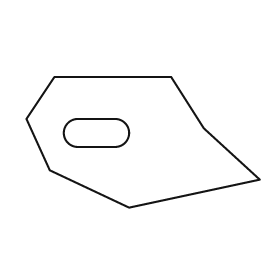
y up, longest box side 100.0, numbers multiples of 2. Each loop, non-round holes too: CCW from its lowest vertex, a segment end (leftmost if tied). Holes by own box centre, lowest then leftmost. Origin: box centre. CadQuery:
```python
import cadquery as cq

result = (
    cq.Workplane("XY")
    .moveTo(-6.0, -28.0)
    .lineTo(50.0, -16.0)
    .lineTo(26.0, 6.0)
    .lineTo(12.0, 28.0)
    .lineTo(-38.0, 28.0)
    .lineTo(-50.0, 10.0)
    .lineTo(-40.0, -12.0)
    .close()
    .moveTo(-28.0, -2.0)
    .lineTo(-12.0, -2.0)
    .threePointArc((-6.0, 4.0), (-12.0, 10.0))
    .lineTo(-28.0, 10.0)
    .threePointArc((-34.0, 4.0), (-28.0, -2.0))
    .close()
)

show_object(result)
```